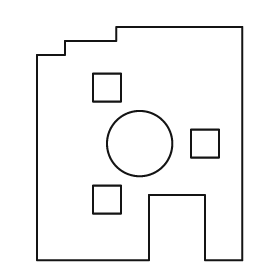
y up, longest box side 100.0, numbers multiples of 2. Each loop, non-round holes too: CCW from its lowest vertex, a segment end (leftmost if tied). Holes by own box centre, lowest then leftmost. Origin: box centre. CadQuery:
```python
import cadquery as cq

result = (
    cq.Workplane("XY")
    .moveTo(-44.0, -50.0)
    .lineTo(4.0, -50.0)
    .lineTo(4.0, -22.0)
    .lineTo(28.0, -22.0)
    .lineTo(28.0, -50.0)
    .lineTo(44.0, -50.0)
    .lineTo(44.0, 50.0)
    .lineTo(-10.0, 50.0)
    .lineTo(-10.0, 44.0)
    .lineTo(-32.0, 44.0)
    .lineTo(-32.0, 38.0)
    .lineTo(-44.0, 38.0)
    .close()
    .moveTo(-20.0, -30.0)
    .lineTo(-8.0, -30.0)
    .lineTo(-8.0, -18.0)
    .lineTo(-20.0, -18.0)
    .close()
    .moveTo(0.0, 0.0)
    .circle(14.0)
    .moveTo(22.0, -6.0)
    .lineTo(34.0, -6.0)
    .lineTo(34.0, 6.0)
    .lineTo(22.0, 6.0)
    .close()
    .moveTo(-20.0, 18.0)
    .lineTo(-8.0, 18.0)
    .lineTo(-8.0, 30.0)
    .lineTo(-20.0, 30.0)
    .close()
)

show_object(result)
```